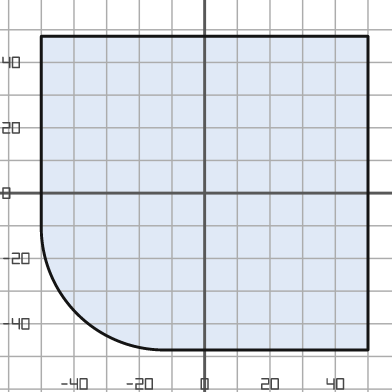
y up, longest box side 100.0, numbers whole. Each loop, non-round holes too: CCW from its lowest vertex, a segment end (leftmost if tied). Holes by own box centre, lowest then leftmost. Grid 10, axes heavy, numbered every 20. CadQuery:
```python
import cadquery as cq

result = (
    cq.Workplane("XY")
    .moveTo(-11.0, -48.0)
    .lineTo(50.0, -48.0)
    .lineTo(50.0, 48.0)
    .lineTo(-50.0, 48.0)
    .lineTo(-50.0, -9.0)
    .threePointArc((-39.0, -37.0), (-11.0, -48.0))
    .close()
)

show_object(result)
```